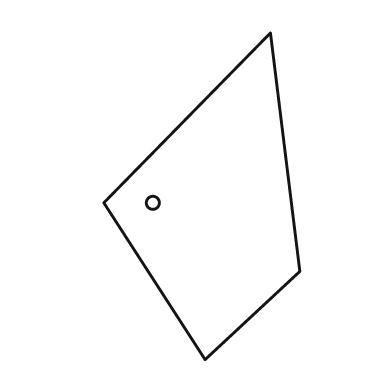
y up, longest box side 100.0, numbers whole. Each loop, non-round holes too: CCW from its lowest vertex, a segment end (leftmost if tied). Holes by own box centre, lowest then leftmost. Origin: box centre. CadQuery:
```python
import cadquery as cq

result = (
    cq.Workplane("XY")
    .moveTo(1.0, -50.0)
    .lineTo(30.0, -23.0)
    .lineTo(21.0, 50.0)
    .lineTo(-30.0, -2.0)
    .close()
    .moveTo(-15.0, -2.0)
    .circle(2.0)
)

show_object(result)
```